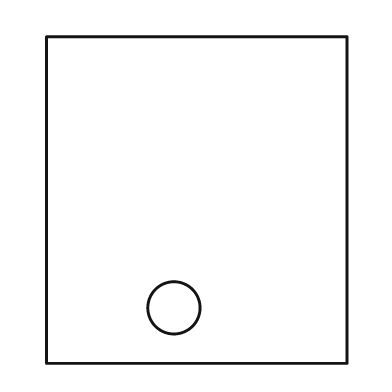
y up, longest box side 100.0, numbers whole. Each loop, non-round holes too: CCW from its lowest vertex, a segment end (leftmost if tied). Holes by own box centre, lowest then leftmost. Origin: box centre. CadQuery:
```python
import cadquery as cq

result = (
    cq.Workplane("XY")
    .moveTo(-46.0, -50.0)
    .lineTo(46.0, -50.0)
    .lineTo(46.0, 50.0)
    .lineTo(-46.0, 50.0)
    .close()
    .moveTo(-7.0, -33.0)
    .circle(8.0)
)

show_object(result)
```